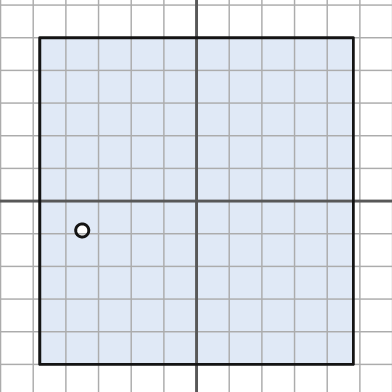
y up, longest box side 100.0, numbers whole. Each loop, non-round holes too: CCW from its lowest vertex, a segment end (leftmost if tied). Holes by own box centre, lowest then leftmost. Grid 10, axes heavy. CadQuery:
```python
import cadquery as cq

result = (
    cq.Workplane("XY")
    .moveTo(-48.0, -50.0)
    .lineTo(48.0, -50.0)
    .lineTo(48.0, 50.0)
    .lineTo(-48.0, 50.0)
    .close()
    .moveTo(-35.0, -9.0)
    .circle(2.0)
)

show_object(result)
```